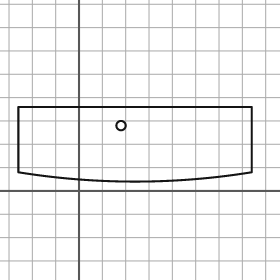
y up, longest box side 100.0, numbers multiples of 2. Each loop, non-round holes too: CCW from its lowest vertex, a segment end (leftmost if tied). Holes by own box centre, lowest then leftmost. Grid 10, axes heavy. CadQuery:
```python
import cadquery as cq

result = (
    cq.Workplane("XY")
    .moveTo(-26.0, 8.0)
    .threePointArc((24.0, 4.0), (74.0, 8.0))
    .lineTo(74.0, 36.0)
    .lineTo(-26.0, 36.0)
    .close()
    .moveTo(18.0, 28.0)
    .circle(2.0)
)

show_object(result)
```